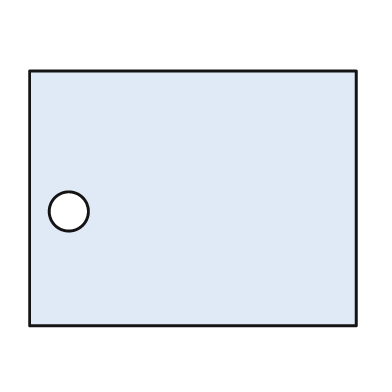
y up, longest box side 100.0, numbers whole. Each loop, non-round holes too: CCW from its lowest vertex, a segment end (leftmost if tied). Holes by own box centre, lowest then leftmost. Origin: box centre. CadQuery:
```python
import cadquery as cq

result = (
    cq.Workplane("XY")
    .moveTo(-50.0, -39.0)
    .lineTo(50.0, -39.0)
    .lineTo(50.0, 39.0)
    .lineTo(-50.0, 39.0)
    .close()
    .moveTo(-38.0, -4.0)
    .circle(6.0)
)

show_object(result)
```